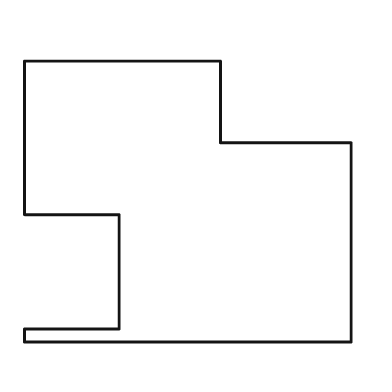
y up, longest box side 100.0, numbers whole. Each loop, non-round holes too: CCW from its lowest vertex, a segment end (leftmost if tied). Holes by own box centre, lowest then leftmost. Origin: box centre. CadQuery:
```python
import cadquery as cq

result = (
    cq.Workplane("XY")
    .moveTo(-50.0, -43.0)
    .lineTo(50.0, -43.0)
    .lineTo(50.0, 18.0)
    .lineTo(10.0, 18.0)
    .lineTo(10.0, 43.0)
    .lineTo(-50.0, 43.0)
    .lineTo(-50.0, -4.0)
    .lineTo(-21.0, -4.0)
    .lineTo(-21.0, -39.0)
    .lineTo(-50.0, -39.0)
    .close()
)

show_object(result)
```